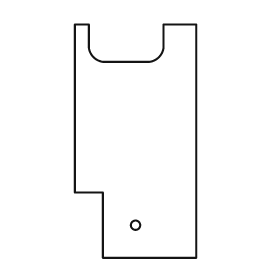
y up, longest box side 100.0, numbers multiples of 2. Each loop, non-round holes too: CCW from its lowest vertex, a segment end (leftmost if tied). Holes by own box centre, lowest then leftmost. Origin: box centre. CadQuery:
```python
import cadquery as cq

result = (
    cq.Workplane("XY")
    .moveTo(-14.0, -50.0)
    .lineTo(26.0, -50.0)
    .lineTo(26.0, 50.0)
    .lineTo(12.0, 50.0)
    .lineTo(12.0, 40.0)
    .threePointArc((10.0, 36.0), (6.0, 34.0))
    .lineTo(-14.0, 34.0)
    .threePointArc((-18.0, 36.0), (-20.0, 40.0))
    .lineTo(-20.0, 50.0)
    .lineTo(-26.0, 50.0)
    .lineTo(-26.0, -22.0)
    .lineTo(-14.0, -22.0)
    .close()
    .moveTo(0.0, -36.0)
    .circle(2.0)
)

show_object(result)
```